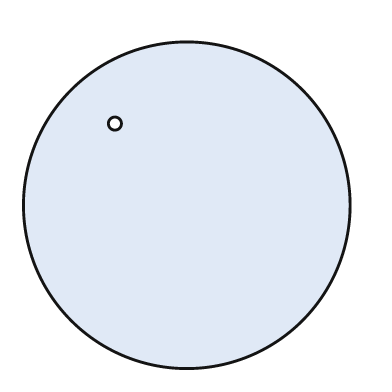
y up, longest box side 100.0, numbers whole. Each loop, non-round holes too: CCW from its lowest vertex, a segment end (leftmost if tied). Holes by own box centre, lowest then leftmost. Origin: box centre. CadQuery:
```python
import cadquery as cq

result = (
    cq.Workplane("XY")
    .moveTo(0.0, 0.0)
    .circle(50.0)
    .moveTo(-22.0, 25.0)
    .circle(2.0)
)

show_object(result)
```